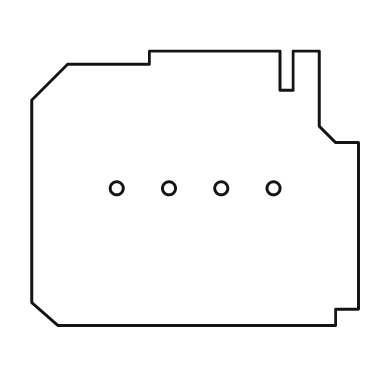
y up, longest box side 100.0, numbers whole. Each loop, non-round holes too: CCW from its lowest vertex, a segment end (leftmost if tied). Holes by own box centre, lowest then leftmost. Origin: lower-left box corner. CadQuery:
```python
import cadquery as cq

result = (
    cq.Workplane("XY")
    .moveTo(8.0, 0.0)
    .lineTo(93.0, 0.0)
    .lineTo(93.0, 5.0)
    .lineTo(100.0, 5.0)
    .lineTo(100.0, 56.0)
    .lineTo(93.0, 56.0)
    .lineTo(88.0, 61.0)
    .lineTo(88.0, 84.0)
    .lineTo(80.0, 84.0)
    .lineTo(80.0, 72.0)
    .lineTo(76.0, 72.0)
    .lineTo(76.0, 84.0)
    .lineTo(36.0, 84.0)
    .lineTo(36.0, 80.0)
    .lineTo(11.0, 80.0)
    .lineTo(0.0, 69.0)
    .lineTo(0.0, 7.0)
    .close()
    .moveTo(26.0, 42.0)
    .circle(2.0)
    .moveTo(42.0, 42.0)
    .circle(2.0)
    .moveTo(58.0, 42.0)
    .circle(2.0)
    .moveTo(74.0, 42.0)
    .circle(2.0)
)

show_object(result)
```